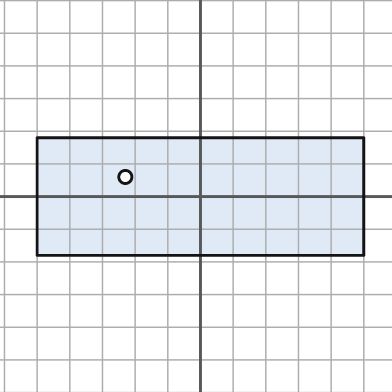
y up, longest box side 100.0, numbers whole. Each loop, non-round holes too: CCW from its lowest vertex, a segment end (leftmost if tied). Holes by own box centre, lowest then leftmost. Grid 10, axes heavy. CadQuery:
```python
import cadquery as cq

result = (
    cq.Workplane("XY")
    .moveTo(-50.0, -18.0)
    .lineTo(50.0, -18.0)
    .lineTo(50.0, 18.0)
    .lineTo(-50.0, 18.0)
    .close()
    .moveTo(-23.0, 6.0)
    .circle(2.0)
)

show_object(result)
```